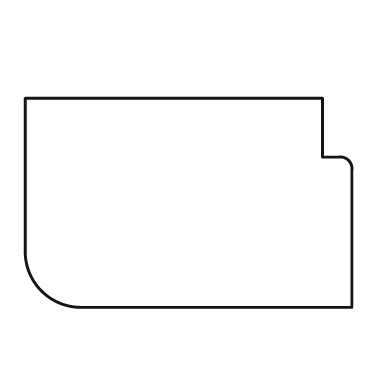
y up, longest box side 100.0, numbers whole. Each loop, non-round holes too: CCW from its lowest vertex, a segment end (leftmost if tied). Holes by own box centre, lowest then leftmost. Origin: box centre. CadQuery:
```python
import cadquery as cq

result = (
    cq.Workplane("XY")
    .moveTo(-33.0, -32.0)
    .lineTo(50.0, -32.0)
    .lineTo(50.0, 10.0)
    .threePointArc((49.0, 13.0), (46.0, 14.0))
    .lineTo(41.0, 14.0)
    .lineTo(41.0, 32.0)
    .lineTo(-50.0, 32.0)
    .lineTo(-50.0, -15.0)
    .threePointArc((-45.0, -27.0), (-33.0, -32.0))
    .close()
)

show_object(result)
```